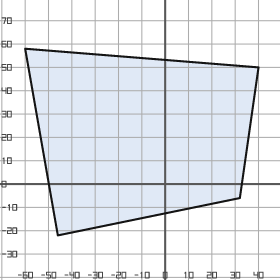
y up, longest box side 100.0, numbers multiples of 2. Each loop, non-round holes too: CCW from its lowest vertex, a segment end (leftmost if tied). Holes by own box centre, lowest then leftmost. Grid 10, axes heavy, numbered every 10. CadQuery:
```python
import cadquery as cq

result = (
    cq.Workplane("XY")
    .moveTo(-46.0, -22.0)
    .lineTo(32.0, -6.0)
    .lineTo(40.0, 50.0)
    .lineTo(-60.0, 58.0)
    .close()
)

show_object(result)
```